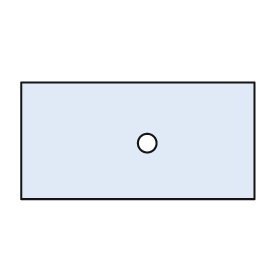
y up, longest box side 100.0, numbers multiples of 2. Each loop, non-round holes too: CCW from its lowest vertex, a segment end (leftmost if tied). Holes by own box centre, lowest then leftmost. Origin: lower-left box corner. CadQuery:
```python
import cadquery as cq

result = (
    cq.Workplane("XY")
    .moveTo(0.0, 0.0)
    .lineTo(100.0, 0.0)
    .lineTo(100.0, 50.0)
    .lineTo(0.0, 50.0)
    .close()
    .moveTo(54.0, 24.0)
    .circle(4.0)
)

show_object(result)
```